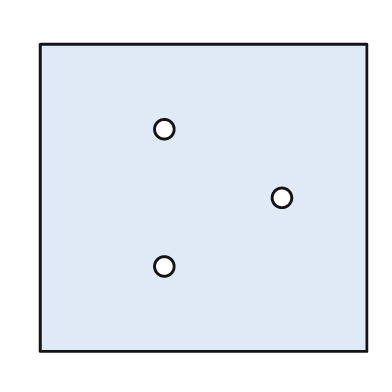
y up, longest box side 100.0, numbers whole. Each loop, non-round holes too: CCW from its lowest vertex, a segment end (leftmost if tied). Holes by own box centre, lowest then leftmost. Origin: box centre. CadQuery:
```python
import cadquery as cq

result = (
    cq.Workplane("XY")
    .moveTo(-50.0, -47.0)
    .lineTo(50.0, -47.0)
    .lineTo(50.0, 47.0)
    .lineTo(-50.0, 47.0)
    .close()
    .moveTo(-12.0, -21.0)
    .circle(3.0)
    .moveTo(24.0, 0.0)
    .circle(3.0)
    .moveTo(-12.0, 21.0)
    .circle(3.0)
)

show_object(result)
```